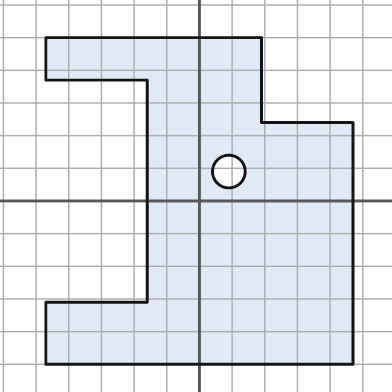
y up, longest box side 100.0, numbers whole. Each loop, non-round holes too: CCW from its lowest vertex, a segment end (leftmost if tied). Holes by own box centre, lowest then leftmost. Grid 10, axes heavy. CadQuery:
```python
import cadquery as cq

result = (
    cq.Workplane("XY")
    .moveTo(-47.0, -50.0)
    .lineTo(47.0, -50.0)
    .lineTo(47.0, 24.0)
    .lineTo(19.0, 24.0)
    .lineTo(19.0, 50.0)
    .lineTo(-47.0, 50.0)
    .lineTo(-47.0, 37.0)
    .lineTo(-16.0, 37.0)
    .lineTo(-16.0, -31.0)
    .lineTo(-47.0, -31.0)
    .close()
    .moveTo(9.0, 9.0)
    .circle(5.0)
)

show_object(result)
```